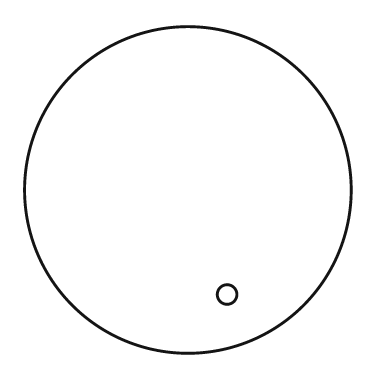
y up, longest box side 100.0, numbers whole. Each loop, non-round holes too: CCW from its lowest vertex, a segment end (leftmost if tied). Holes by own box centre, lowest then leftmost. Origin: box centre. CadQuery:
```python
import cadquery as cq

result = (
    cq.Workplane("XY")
    .moveTo(0.0, 0.0)
    .circle(50.0)
    .moveTo(12.0, -32.0)
    .circle(3.0)
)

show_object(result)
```